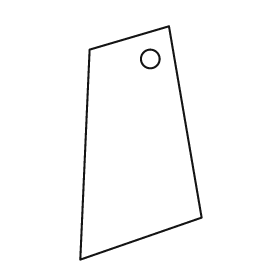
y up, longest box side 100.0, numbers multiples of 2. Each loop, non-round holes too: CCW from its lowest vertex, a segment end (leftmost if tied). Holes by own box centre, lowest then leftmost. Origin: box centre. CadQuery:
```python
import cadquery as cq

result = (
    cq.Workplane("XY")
    .moveTo(-26.0, -50.0)
    .lineTo(26.0, -32.0)
    .lineTo(12.0, 50.0)
    .lineTo(-22.0, 40.0)
    .close()
    .moveTo(4.0, 36.0)
    .circle(4.0)
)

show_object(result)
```